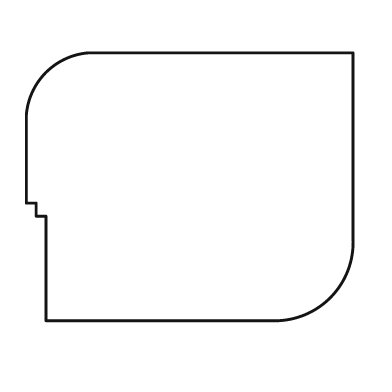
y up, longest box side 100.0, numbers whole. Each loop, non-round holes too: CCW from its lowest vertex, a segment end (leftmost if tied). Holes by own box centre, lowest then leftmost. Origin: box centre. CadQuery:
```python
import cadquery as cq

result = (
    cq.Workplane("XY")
    .moveTo(-44.0, -41.0)
    .lineTo(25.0, -41.0)
    .threePointArc((43.0, -34.0), (50.0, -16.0))
    .lineTo(50.0, 41.0)
    .lineTo(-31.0, 41.0)
    .threePointArc((-44.0, 35.0), (-50.0, 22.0))
    .lineTo(-50.0, -5.0)
    .lineTo(-47.0, -5.0)
    .lineTo(-47.0, -9.0)
    .lineTo(-44.0, -9.0)
    .close()
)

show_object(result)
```